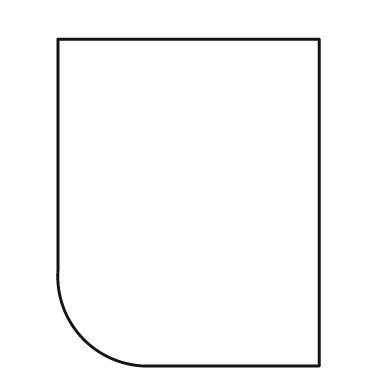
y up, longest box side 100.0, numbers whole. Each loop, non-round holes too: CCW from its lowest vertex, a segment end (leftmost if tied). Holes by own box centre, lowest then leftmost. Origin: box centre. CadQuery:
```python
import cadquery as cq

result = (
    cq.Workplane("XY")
    .moveTo(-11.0, -50.0)
    .lineTo(40.0, -50.0)
    .lineTo(40.0, 50.0)
    .lineTo(-40.0, 50.0)
    .lineTo(-40.0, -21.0)
    .threePointArc((-32.0, -42.0), (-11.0, -50.0))
    .close()
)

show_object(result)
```